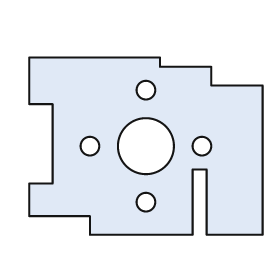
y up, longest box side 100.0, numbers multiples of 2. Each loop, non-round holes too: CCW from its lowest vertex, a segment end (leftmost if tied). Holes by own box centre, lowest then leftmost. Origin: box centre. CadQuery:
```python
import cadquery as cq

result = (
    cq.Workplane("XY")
    .moveTo(-24.0, -38.0)
    .lineTo(20.0, -38.0)
    .lineTo(20.0, -10.0)
    .lineTo(26.0, -10.0)
    .lineTo(26.0, -38.0)
    .lineTo(50.0, -38.0)
    .lineTo(50.0, 26.0)
    .lineTo(28.0, 26.0)
    .lineTo(28.0, 34.0)
    .lineTo(6.0, 34.0)
    .lineTo(6.0, 38.0)
    .lineTo(-50.0, 38.0)
    .lineTo(-50.0, 18.0)
    .lineTo(-40.0, 18.0)
    .lineTo(-40.0, -16.0)
    .lineTo(-50.0, -16.0)
    .lineTo(-50.0, -30.0)
    .lineTo(-24.0, -30.0)
    .close()
    .moveTo(0.0, -24.0)
    .circle(4.0)
    .moveTo(-24.0, 0.0)
    .circle(4.0)
    .moveTo(0.0, 0.0)
    .circle(12.0)
    .moveTo(24.0, 0.0)
    .circle(4.0)
    .moveTo(0.0, 24.0)
    .circle(4.0)
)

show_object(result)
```